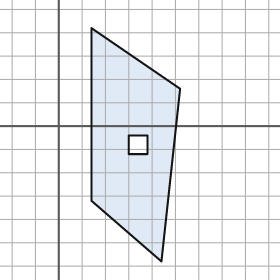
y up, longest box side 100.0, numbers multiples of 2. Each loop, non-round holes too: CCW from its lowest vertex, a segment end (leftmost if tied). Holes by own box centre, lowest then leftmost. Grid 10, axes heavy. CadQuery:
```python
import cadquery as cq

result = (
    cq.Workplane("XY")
    .moveTo(44.0, -58.0)
    .lineTo(52.0, 16.0)
    .lineTo(14.0, 42.0)
    .lineTo(14.0, -32.0)
    .close()
    .moveTo(30.0, -12.0)
    .lineTo(38.0, -12.0)
    .lineTo(38.0, -4.0)
    .lineTo(30.0, -4.0)
    .close()
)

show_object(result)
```